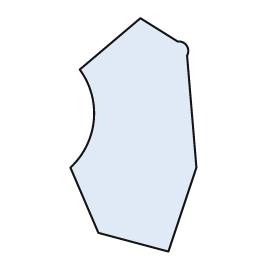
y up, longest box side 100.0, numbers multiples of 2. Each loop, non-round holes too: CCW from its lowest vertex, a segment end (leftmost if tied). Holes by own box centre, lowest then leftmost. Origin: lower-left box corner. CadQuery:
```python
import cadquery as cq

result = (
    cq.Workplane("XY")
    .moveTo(42.0, 0.0)
    .lineTo(54.0, 36.0)
    .lineTo(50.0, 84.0)
    .threePointArc((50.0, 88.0), (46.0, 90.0))
    .lineTo(30.0, 100.0)
    .lineTo(4.0, 78.0)
    .threePointArc((10.0, 56.0), (0.0, 36.0))
    .lineTo(12.0, 8.0)
    .close()
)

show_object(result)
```